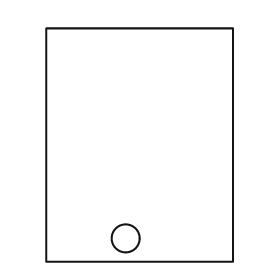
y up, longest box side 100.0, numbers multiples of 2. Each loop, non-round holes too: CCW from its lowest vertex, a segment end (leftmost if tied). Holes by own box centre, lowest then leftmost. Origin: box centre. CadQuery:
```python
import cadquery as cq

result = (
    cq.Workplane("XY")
    .moveTo(-40.0, -50.0)
    .lineTo(40.0, -50.0)
    .lineTo(40.0, 50.0)
    .lineTo(-40.0, 50.0)
    .close()
    .moveTo(-6.0, -40.0)
    .circle(6.0)
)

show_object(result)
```